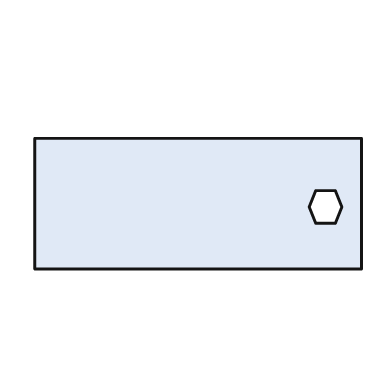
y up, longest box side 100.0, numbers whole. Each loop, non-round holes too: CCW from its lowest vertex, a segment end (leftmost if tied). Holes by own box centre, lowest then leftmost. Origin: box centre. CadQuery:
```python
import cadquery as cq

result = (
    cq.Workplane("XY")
    .moveTo(-50.0, -20.0)
    .lineTo(50.0, -20.0)
    .lineTo(50.0, 20.0)
    .lineTo(-50.0, 20.0)
    .close()
    .moveTo(36.0, -6.0)
    .lineTo(42.0, -6.0)
    .lineTo(44.0, -1.0)
    .lineTo(42.0, 4.0)
    .lineTo(36.0, 4.0)
    .lineTo(34.0, -1.0)
    .close()
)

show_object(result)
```